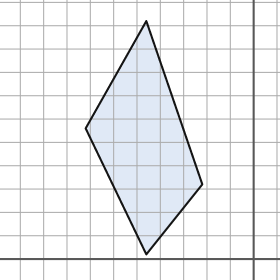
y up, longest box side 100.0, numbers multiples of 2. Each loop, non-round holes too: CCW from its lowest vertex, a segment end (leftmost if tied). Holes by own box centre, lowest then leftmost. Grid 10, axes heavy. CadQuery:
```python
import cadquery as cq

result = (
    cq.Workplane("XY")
    .moveTo(-46.0, 2.0)
    .lineTo(-22.0, 32.0)
    .lineTo(-46.0, 102.0)
    .lineTo(-72.0, 56.0)
    .close()
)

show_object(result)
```